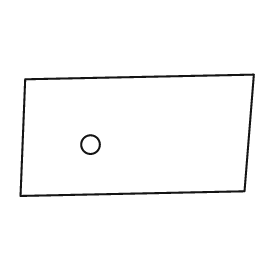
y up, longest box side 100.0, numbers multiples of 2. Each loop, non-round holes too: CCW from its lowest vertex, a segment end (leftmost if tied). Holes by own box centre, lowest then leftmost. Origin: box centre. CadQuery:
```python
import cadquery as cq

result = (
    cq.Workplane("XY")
    .moveTo(-50.0, -26.0)
    .lineTo(46.0, -24.0)
    .lineTo(50.0, 26.0)
    .lineTo(-48.0, 24.0)
    .close()
    .moveTo(-20.0, -4.0)
    .circle(4.0)
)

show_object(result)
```